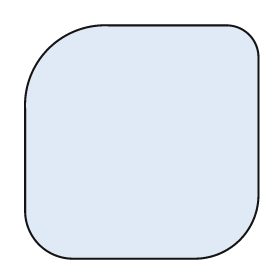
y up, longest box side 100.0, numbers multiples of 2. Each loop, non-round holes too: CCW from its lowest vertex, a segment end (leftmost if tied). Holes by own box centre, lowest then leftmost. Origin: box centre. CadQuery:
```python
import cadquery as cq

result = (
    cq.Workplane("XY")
    .moveTo(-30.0, -50.0)
    .lineTo(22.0, -50.0)
    .threePointArc((42.0, -42.0), (50.0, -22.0))
    .lineTo(50.0, 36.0)
    .threePointArc((46.0, 46.0), (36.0, 50.0))
    .lineTo(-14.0, 50.0)
    .threePointArc((-40.0, 40.0), (-50.0, 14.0))
    .lineTo(-50.0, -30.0)
    .threePointArc((-44.0, -44.0), (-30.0, -50.0))
    .close()
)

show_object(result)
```